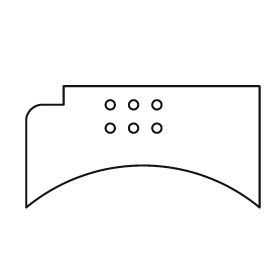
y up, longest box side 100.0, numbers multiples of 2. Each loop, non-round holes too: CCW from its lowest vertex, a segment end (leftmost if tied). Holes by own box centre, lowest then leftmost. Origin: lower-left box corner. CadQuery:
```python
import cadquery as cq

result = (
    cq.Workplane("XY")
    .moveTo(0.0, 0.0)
    .threePointArc((50.0, 18.0), (100.0, 0.0))
    .lineTo(100.0, 52.0)
    .lineTo(16.0, 52.0)
    .lineTo(16.0, 44.0)
    .lineTo(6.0, 44.0)
    .threePointArc((2.0, 42.0), (0.0, 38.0))
    .close()
    .moveTo(36.0, 34.0)
    .circle(2.0)
    .moveTo(46.0, 34.0)
    .circle(2.0)
    .moveTo(56.0, 34.0)
    .circle(2.0)
    .moveTo(36.0, 44.0)
    .circle(2.0)
    .moveTo(46.0, 44.0)
    .circle(2.0)
    .moveTo(56.0, 44.0)
    .circle(2.0)
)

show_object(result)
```